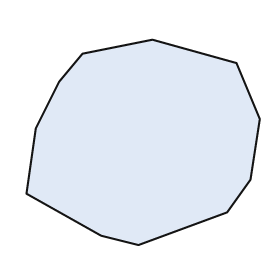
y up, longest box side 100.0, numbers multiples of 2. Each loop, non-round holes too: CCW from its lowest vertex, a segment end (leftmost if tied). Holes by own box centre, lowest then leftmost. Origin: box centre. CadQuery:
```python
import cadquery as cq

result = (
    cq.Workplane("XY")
    .moveTo(-2.0, -44.0)
    .lineTo(36.0, -30.0)
    .lineTo(46.0, -16.0)
    .lineTo(50.0, 10.0)
    .lineTo(40.0, 34.0)
    .lineTo(4.0, 44.0)
    .lineTo(-26.0, 38.0)
    .lineTo(-36.0, 26.0)
    .lineTo(-46.0, 6.0)
    .lineTo(-50.0, -22.0)
    .lineTo(-18.0, -40.0)
    .close()
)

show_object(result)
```